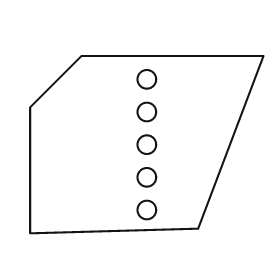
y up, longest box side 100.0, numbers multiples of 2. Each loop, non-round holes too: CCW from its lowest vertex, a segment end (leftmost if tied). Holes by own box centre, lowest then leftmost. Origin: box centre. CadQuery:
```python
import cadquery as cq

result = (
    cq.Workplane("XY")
    .moveTo(-50.0, -38.0)
    .lineTo(22.0, -36.0)
    .lineTo(50.0, 38.0)
    .lineTo(-28.0, 38.0)
    .lineTo(-50.0, 16.0)
    .close()
    .moveTo(0.0, -28.0)
    .circle(4.0)
    .moveTo(0.0, -14.0)
    .circle(4.0)
    .moveTo(0.0, 0.0)
    .circle(4.0)
    .moveTo(0.0, 14.0)
    .circle(4.0)
    .moveTo(0.0, 28.0)
    .circle(4.0)
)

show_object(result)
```